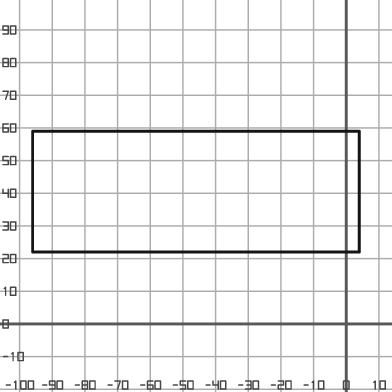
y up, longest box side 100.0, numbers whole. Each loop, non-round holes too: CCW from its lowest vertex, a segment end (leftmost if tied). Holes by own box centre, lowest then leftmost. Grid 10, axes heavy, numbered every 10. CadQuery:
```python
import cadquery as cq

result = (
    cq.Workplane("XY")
    .moveTo(-96.0, 22.0)
    .lineTo(4.0, 22.0)
    .lineTo(4.0, 59.0)
    .lineTo(-96.0, 59.0)
    .close()
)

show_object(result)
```